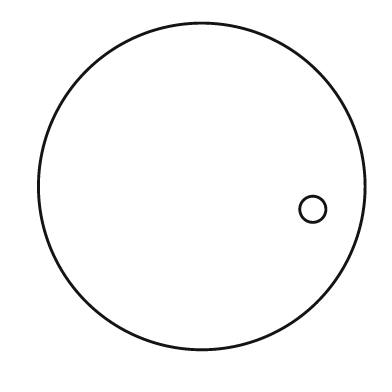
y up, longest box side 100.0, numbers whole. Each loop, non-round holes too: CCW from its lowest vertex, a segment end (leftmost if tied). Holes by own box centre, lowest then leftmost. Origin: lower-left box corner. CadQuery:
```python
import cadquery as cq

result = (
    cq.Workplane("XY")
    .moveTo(50.0, 50.0)
    .circle(50.0)
    .moveTo(84.0, 43.0)
    .circle(4.0)
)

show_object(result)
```